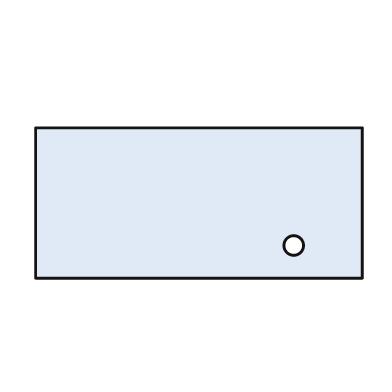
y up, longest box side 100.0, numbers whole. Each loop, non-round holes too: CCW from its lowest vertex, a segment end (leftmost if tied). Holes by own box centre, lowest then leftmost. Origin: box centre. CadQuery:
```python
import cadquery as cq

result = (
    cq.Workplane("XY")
    .moveTo(-50.0, -23.0)
    .lineTo(50.0, -23.0)
    .lineTo(50.0, 23.0)
    .lineTo(-50.0, 23.0)
    .close()
    .moveTo(29.0, -13.0)
    .circle(3.0)
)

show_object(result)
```